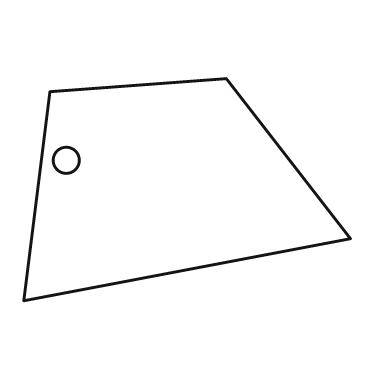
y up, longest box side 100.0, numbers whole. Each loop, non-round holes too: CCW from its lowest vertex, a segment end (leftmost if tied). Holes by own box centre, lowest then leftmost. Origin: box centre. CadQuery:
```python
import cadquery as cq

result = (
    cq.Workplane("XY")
    .moveTo(-50.0, -34.0)
    .lineTo(50.0, -15.0)
    .lineTo(12.0, 34.0)
    .lineTo(-42.0, 30.0)
    .close()
    .moveTo(-37.0, 9.0)
    .circle(4.0)
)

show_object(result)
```